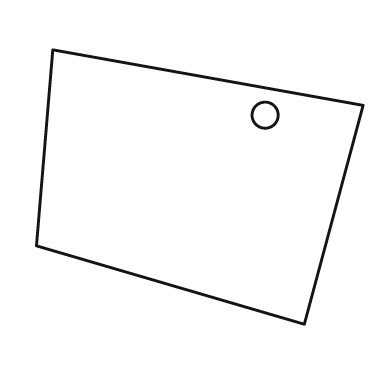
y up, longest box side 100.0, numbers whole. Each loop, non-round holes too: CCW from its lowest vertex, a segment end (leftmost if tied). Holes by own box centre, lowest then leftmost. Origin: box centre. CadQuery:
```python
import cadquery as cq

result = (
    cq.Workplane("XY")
    .moveTo(32.0, -42.0)
    .lineTo(50.0, 25.0)
    .lineTo(-45.0, 42.0)
    .lineTo(-50.0, -18.0)
    .close()
    .moveTo(20.0, 22.0)
    .circle(4.0)
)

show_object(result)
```